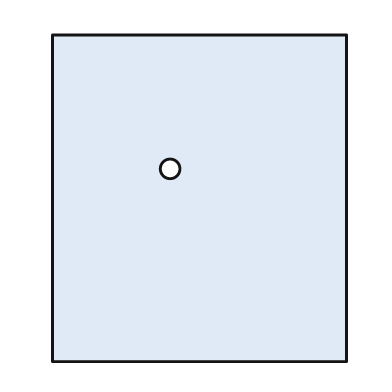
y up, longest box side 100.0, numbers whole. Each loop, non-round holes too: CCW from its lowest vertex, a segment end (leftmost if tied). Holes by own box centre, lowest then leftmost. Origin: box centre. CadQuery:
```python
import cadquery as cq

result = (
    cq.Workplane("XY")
    .moveTo(-45.0, -50.0)
    .lineTo(45.0, -50.0)
    .lineTo(45.0, 50.0)
    .lineTo(-45.0, 50.0)
    .close()
    .moveTo(-9.0, 9.0)
    .circle(3.0)
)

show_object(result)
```